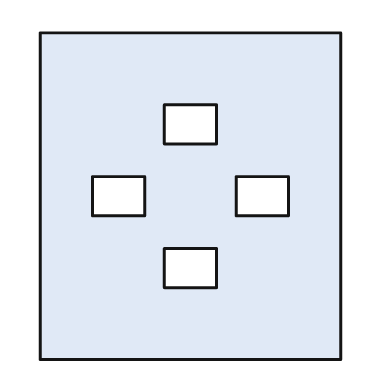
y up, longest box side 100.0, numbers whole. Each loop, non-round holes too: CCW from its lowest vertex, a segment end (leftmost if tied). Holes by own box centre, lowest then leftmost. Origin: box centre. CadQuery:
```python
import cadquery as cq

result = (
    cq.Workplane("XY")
    .moveTo(-46.0, -50.0)
    .lineTo(46.0, -50.0)
    .lineTo(46.0, 50.0)
    .lineTo(-46.0, 50.0)
    .close()
    .moveTo(-8.0, -28.0)
    .lineTo(8.0, -28.0)
    .lineTo(8.0, -16.0)
    .lineTo(-8.0, -16.0)
    .close()
    .moveTo(-30.0, -6.0)
    .lineTo(-14.0, -6.0)
    .lineTo(-14.0, 6.0)
    .lineTo(-30.0, 6.0)
    .close()
    .moveTo(14.0, -6.0)
    .lineTo(30.0, -6.0)
    .lineTo(30.0, 6.0)
    .lineTo(14.0, 6.0)
    .close()
    .moveTo(-8.0, 16.0)
    .lineTo(8.0, 16.0)
    .lineTo(8.0, 28.0)
    .lineTo(-8.0, 28.0)
    .close()
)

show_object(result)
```